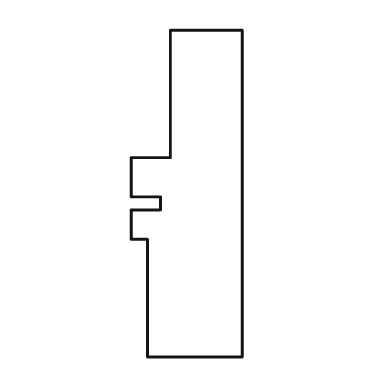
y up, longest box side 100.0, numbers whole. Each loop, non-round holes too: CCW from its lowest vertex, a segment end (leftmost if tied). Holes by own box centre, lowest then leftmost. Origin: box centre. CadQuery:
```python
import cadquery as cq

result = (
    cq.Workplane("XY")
    .moveTo(-12.0, -50.0)
    .lineTo(17.0, -50.0)
    .lineTo(17.0, 50.0)
    .lineTo(-5.0, 50.0)
    .lineTo(-5.0, 11.0)
    .lineTo(-17.0, 11.0)
    .lineTo(-17.0, -1.0)
    .lineTo(-8.0, -1.0)
    .lineTo(-8.0, -5.0)
    .lineTo(-17.0, -5.0)
    .lineTo(-17.0, -14.0)
    .lineTo(-12.0, -14.0)
    .close()
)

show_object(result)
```